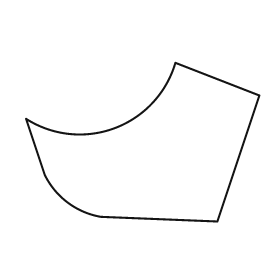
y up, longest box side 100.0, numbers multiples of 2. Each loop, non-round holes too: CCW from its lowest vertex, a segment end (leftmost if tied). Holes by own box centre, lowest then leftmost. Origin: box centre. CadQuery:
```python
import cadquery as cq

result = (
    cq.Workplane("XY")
    .moveTo(32.0, -34.0)
    .lineTo(50.0, 20.0)
    .lineTo(14.0, 34.0)
    .threePointArc((-12.0, 6.0), (-50.0, 10.0))
    .lineTo(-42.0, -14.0)
    .threePointArc((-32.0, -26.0), (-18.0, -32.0))
    .close()
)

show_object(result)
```